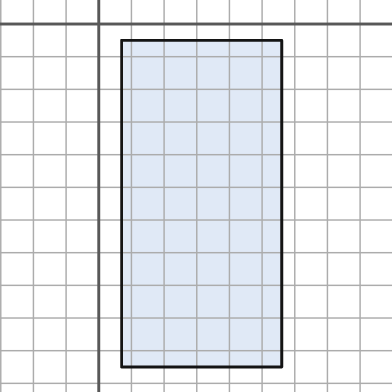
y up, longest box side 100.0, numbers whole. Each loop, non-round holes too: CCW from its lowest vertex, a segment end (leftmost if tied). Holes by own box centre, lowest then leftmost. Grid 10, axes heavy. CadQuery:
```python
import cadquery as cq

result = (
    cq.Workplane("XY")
    .moveTo(7.0, -105.0)
    .lineTo(56.0, -105.0)
    .lineTo(56.0, -5.0)
    .lineTo(7.0, -5.0)
    .close()
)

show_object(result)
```